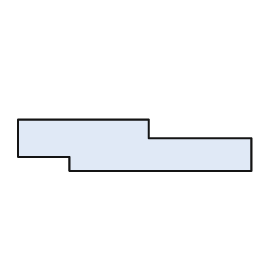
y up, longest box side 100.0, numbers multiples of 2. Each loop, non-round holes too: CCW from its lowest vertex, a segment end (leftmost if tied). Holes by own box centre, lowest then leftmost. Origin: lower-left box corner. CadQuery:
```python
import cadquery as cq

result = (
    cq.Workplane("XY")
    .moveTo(22.0, 0.0)
    .lineTo(100.0, 0.0)
    .lineTo(100.0, 14.0)
    .lineTo(56.0, 14.0)
    .lineTo(56.0, 22.0)
    .lineTo(0.0, 22.0)
    .lineTo(0.0, 6.0)
    .lineTo(22.0, 6.0)
    .close()
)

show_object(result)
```